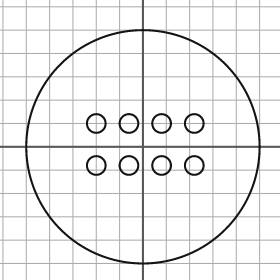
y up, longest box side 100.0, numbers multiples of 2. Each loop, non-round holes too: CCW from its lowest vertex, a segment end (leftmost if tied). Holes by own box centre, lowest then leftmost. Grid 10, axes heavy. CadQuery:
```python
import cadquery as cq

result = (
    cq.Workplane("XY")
    .moveTo(0.0, 0.0)
    .circle(50.0)
    .moveTo(-20.0, -8.0)
    .circle(4.0)
    .moveTo(-6.0, -8.0)
    .circle(4.0)
    .moveTo(8.0, -8.0)
    .circle(4.0)
    .moveTo(22.0, -8.0)
    .circle(4.0)
    .moveTo(-20.0, 10.0)
    .circle(4.0)
    .moveTo(-6.0, 10.0)
    .circle(4.0)
    .moveTo(8.0, 10.0)
    .circle(4.0)
    .moveTo(22.0, 10.0)
    .circle(4.0)
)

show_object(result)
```